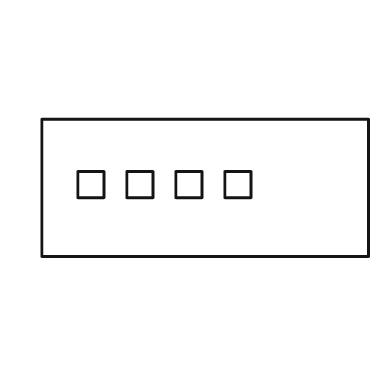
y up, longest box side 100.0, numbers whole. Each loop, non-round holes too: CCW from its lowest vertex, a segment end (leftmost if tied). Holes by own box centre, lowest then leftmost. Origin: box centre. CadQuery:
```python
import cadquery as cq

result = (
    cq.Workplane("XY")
    .moveTo(-50.0, -21.0)
    .lineTo(50.0, -21.0)
    .lineTo(50.0, 21.0)
    .lineTo(-50.0, 21.0)
    .close()
    .moveTo(-39.0, -3.0)
    .lineTo(-31.0, -3.0)
    .lineTo(-31.0, 5.0)
    .lineTo(-39.0, 5.0)
    .close()
    .moveTo(-24.0, -3.0)
    .lineTo(-16.0, -3.0)
    .lineTo(-16.0, 5.0)
    .lineTo(-24.0, 5.0)
    .close()
    .moveTo(-9.0, -3.0)
    .lineTo(-1.0, -3.0)
    .lineTo(-1.0, 5.0)
    .lineTo(-9.0, 5.0)
    .close()
    .moveTo(6.0, -3.0)
    .lineTo(14.0, -3.0)
    .lineTo(14.0, 5.0)
    .lineTo(6.0, 5.0)
    .close()
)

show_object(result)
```